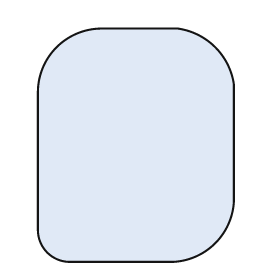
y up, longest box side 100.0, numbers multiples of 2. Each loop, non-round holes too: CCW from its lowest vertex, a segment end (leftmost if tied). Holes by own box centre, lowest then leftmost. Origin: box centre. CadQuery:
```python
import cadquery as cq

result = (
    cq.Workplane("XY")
    .moveTo(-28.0, -50.0)
    .lineTo(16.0, -50.0)
    .threePointArc((34.0, -42.0), (42.0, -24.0))
    .lineTo(42.0, 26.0)
    .threePointArc((34.0, 42.0), (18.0, 50.0))
    .lineTo(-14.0, 50.0)
    .threePointArc((-34.0, 42.0), (-42.0, 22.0))
    .lineTo(-42.0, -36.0)
    .threePointArc((-38.0, -46.0), (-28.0, -50.0))
    .close()
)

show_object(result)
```